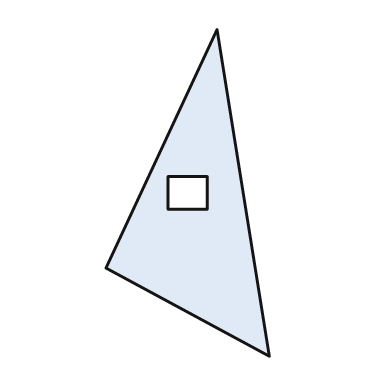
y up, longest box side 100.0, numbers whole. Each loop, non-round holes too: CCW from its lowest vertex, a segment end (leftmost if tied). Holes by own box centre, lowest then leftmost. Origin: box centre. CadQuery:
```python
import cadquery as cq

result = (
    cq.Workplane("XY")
    .moveTo(25.0, -50.0)
    .lineTo(9.0, 50.0)
    .lineTo(-25.0, -23.0)
    .close()
    .moveTo(-6.0, -5.0)
    .lineTo(6.0, -5.0)
    .lineTo(6.0, 5.0)
    .lineTo(-6.0, 5.0)
    .close()
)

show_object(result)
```